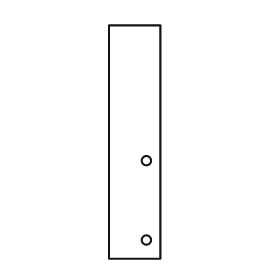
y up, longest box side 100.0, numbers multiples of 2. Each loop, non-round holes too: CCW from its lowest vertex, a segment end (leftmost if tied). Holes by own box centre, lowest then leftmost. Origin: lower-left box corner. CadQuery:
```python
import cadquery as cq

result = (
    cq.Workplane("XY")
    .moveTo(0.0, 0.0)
    .lineTo(22.0, 0.0)
    .lineTo(22.0, 100.0)
    .lineTo(0.0, 100.0)
    .close()
    .moveTo(16.0, 8.0)
    .circle(2.0)
    .moveTo(16.0, 42.0)
    .circle(2.0)
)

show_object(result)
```